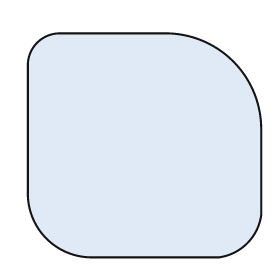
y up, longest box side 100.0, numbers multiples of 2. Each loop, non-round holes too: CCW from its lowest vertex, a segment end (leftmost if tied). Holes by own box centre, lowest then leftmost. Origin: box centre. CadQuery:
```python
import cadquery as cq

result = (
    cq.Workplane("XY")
    .moveTo(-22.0, -48.0)
    .lineTo(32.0, -48.0)
    .threePointArc((44.0, -42.0), (50.0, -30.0))
    .lineTo(50.0, 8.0)
    .threePointArc((38.0, 36.0), (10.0, 48.0))
    .lineTo(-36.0, 48.0)
    .threePointArc((-46.0, 44.0), (-50.0, 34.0))
    .lineTo(-50.0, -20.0)
    .threePointArc((-42.0, -40.0), (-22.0, -48.0))
    .close()
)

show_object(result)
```